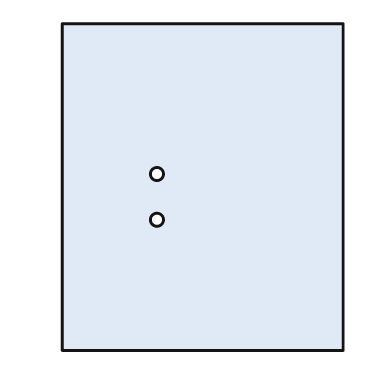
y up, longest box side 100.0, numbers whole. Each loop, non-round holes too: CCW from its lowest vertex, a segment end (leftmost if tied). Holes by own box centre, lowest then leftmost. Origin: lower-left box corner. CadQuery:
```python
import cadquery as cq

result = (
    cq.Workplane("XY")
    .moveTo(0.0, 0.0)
    .lineTo(86.0, 0.0)
    .lineTo(86.0, 100.0)
    .lineTo(0.0, 100.0)
    .close()
    .moveTo(29.0, 40.0)
    .circle(2.0)
    .moveTo(29.0, 54.0)
    .circle(2.0)
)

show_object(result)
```